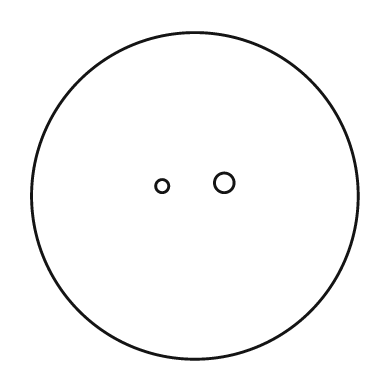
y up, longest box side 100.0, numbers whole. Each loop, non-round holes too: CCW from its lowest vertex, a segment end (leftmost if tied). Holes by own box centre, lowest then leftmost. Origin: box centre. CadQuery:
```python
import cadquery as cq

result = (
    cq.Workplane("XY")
    .moveTo(0.0, 0.0)
    .circle(50.0)
    .moveTo(-10.0, 3.0)
    .circle(2.0)
    .moveTo(9.0, 4.0)
    .circle(3.0)
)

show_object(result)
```